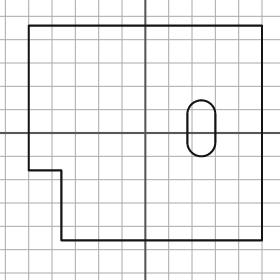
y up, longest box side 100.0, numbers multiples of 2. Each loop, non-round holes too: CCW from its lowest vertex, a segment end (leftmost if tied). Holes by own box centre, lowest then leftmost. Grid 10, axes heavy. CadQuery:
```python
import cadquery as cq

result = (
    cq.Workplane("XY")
    .moveTo(-36.0, -46.0)
    .lineTo(50.0, -46.0)
    .lineTo(50.0, 46.0)
    .lineTo(-50.0, 46.0)
    .lineTo(-50.0, -16.0)
    .lineTo(-36.0, -16.0)
    .close()
    .moveTo(18.0, -4.0)
    .threePointArc((24.0, -10.0), (30.0, -4.0))
    .lineTo(30.0, 8.0)
    .threePointArc((24.0, 14.0), (18.0, 8.0))
    .close()
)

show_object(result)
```